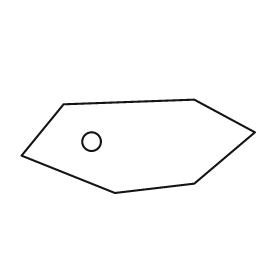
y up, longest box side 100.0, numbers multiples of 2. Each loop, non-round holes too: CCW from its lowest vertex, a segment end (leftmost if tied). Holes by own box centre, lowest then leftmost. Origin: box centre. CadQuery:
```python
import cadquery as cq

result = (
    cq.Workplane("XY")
    .moveTo(-10.0, -20.0)
    .lineTo(24.0, -16.0)
    .lineTo(50.0, 6.0)
    .lineTo(24.0, 20.0)
    .lineTo(-32.0, 18.0)
    .lineTo(-50.0, -4.0)
    .close()
    .moveTo(-20.0, 2.0)
    .circle(4.0)
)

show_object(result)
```